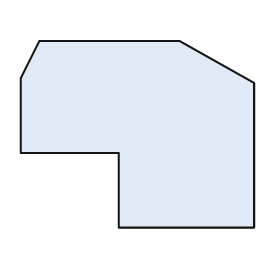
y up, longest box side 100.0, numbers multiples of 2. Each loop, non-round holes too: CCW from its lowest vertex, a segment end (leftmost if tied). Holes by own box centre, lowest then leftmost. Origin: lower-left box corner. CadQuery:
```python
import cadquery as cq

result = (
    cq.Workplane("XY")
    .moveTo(42.0, 0.0)
    .lineTo(100.0, 0.0)
    .lineTo(100.0, 62.0)
    .lineTo(68.0, 80.0)
    .lineTo(8.0, 80.0)
    .lineTo(0.0, 64.0)
    .lineTo(0.0, 32.0)
    .lineTo(42.0, 32.0)
    .close()
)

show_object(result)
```